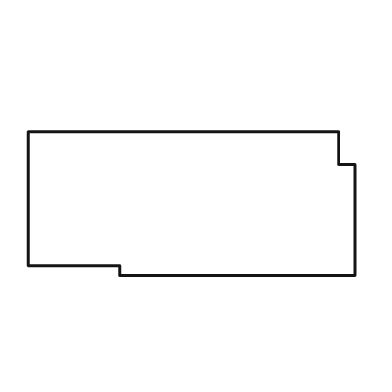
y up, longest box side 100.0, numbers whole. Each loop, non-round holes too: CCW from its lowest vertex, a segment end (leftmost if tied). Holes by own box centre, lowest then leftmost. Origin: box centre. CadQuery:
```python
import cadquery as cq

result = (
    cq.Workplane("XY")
    .moveTo(-22.0, -22.0)
    .lineTo(50.0, -22.0)
    .lineTo(50.0, 12.0)
    .lineTo(45.0, 12.0)
    .lineTo(45.0, 22.0)
    .lineTo(-50.0, 22.0)
    .lineTo(-50.0, -19.0)
    .lineTo(-22.0, -19.0)
    .close()
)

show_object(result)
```